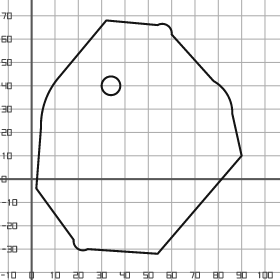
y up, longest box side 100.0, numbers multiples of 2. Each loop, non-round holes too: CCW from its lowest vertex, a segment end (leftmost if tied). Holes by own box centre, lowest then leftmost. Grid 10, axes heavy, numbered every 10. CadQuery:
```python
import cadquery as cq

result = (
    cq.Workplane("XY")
    .moveTo(54.0, -32.0)
    .lineTo(90.0, 10.0)
    .lineTo(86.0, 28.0)
    .threePointArc((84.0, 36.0), (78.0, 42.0))
    .lineTo(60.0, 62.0)
    .threePointArc((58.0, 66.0), (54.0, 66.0))
    .lineTo(32.0, 68.0)
    .lineTo(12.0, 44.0)
    .threePointArc((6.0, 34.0), (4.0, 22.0))
    .lineTo(2.0, -4.0)
    .lineTo(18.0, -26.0)
    .threePointArc((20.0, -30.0), (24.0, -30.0))
    .close()
    .moveTo(34.0, 40.0)
    .circle(4.0)
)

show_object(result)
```